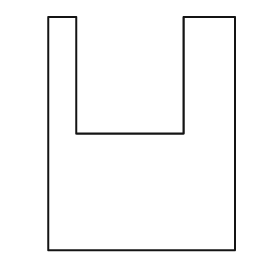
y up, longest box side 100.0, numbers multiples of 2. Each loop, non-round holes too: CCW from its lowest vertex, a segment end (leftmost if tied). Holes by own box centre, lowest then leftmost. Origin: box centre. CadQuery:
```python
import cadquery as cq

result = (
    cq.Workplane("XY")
    .moveTo(-40.0, -50.0)
    .lineTo(40.0, -50.0)
    .lineTo(40.0, 50.0)
    .lineTo(18.0, 50.0)
    .lineTo(18.0, 0.0)
    .lineTo(-28.0, 0.0)
    .lineTo(-28.0, 50.0)
    .lineTo(-40.0, 50.0)
    .close()
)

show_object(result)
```